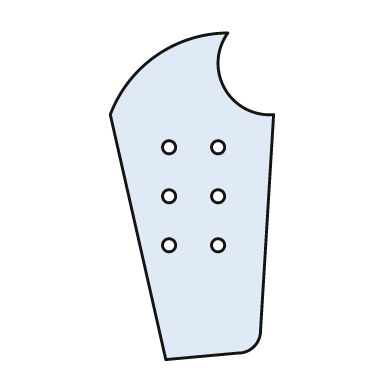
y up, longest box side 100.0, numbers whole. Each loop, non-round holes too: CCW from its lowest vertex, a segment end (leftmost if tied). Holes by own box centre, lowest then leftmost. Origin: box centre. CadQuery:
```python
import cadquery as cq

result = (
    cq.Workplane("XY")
    .moveTo(-8.0, -50.0)
    .lineTo(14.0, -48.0)
    .threePointArc((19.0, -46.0), (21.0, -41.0))
    .lineTo(25.0, 25.0)
    .threePointArc((10.0, 33.0), (11.0, 50.0))
    .threePointArc((-11.0, 43.0), (-25.0, 25.0))
    .close()
    .moveTo(-7.0, -15.0)
    .circle(2.0)
    .moveTo(8.0, -15.0)
    .circle(2.0)
    .moveTo(-7.0, 0.0)
    .circle(2.0)
    .moveTo(8.0, 0.0)
    .circle(2.0)
    .moveTo(-7.0, 15.0)
    .circle(2.0)
    .moveTo(8.0, 15.0)
    .circle(2.0)
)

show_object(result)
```